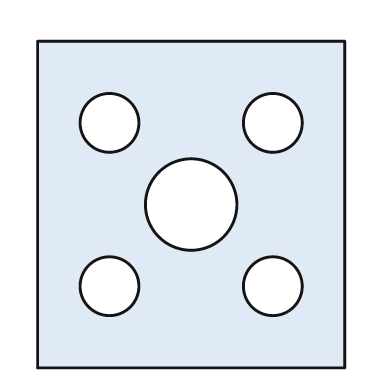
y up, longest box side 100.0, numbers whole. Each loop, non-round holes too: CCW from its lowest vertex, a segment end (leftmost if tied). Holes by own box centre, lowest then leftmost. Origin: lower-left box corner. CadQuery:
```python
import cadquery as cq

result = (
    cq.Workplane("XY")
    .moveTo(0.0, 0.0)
    .lineTo(94.0, 0.0)
    .lineTo(94.0, 100.0)
    .lineTo(0.0, 100.0)
    .close()
    .moveTo(22.0, 25.0)
    .circle(9.0)
    .moveTo(72.0, 25.0)
    .circle(9.0)
    .moveTo(47.0, 50.0)
    .circle(14.0)
    .moveTo(22.0, 75.0)
    .circle(9.0)
    .moveTo(72.0, 75.0)
    .circle(9.0)
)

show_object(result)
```